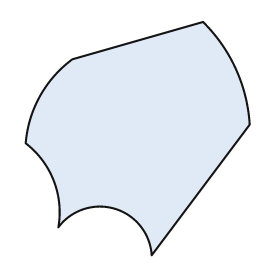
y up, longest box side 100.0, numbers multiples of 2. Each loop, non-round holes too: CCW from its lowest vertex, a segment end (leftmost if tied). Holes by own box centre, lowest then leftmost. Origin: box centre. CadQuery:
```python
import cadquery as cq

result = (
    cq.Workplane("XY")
    .moveTo(6.0, -50.0)
    .lineTo(48.0, 6.0)
    .threePointArc((42.0, 30.0), (28.0, 50.0))
    .lineTo(-28.0, 34.0)
    .threePointArc((-42.0, 18.0), (-48.0, -2.0))
    .threePointArc((-36.0, -18.0), (-34.0, -38.0))
    .threePointArc((-10.0, -30.0), (6.0, -50.0))
    .close()
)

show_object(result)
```